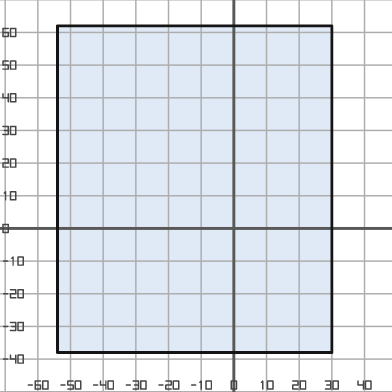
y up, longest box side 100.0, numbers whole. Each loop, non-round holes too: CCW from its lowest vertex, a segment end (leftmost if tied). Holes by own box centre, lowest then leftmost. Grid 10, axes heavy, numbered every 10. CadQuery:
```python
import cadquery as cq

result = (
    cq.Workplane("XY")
    .moveTo(-54.0, -38.0)
    .lineTo(30.0, -38.0)
    .lineTo(30.0, 62.0)
    .lineTo(-54.0, 62.0)
    .close()
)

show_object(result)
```